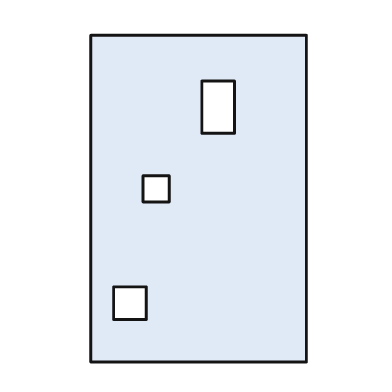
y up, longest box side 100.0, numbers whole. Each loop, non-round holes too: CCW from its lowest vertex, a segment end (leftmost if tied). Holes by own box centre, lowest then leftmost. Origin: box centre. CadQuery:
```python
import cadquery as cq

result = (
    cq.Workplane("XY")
    .moveTo(-33.0, -50.0)
    .lineTo(33.0, -50.0)
    .lineTo(33.0, 50.0)
    .lineTo(-33.0, 50.0)
    .close()
    .moveTo(-26.0, -37.0)
    .lineTo(-16.0, -37.0)
    .lineTo(-16.0, -27.0)
    .lineTo(-26.0, -27.0)
    .close()
    .moveTo(-17.0, -1.0)
    .lineTo(-9.0, -1.0)
    .lineTo(-9.0, 7.0)
    .lineTo(-17.0, 7.0)
    .close()
    .moveTo(1.0, 20.0)
    .lineTo(11.0, 20.0)
    .lineTo(11.0, 36.0)
    .lineTo(1.0, 36.0)
    .close()
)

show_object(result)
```